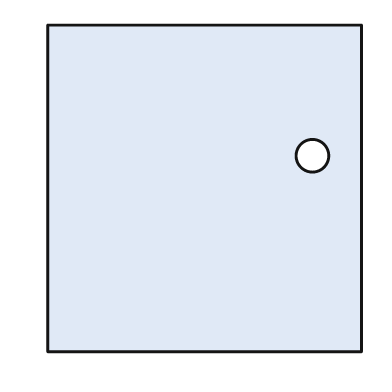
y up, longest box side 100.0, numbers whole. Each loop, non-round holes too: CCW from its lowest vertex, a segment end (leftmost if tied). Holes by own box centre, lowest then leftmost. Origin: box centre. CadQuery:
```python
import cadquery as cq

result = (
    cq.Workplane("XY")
    .moveTo(-48.0, -50.0)
    .lineTo(48.0, -50.0)
    .lineTo(48.0, 50.0)
    .lineTo(-48.0, 50.0)
    .close()
    .moveTo(33.0, 10.0)
    .circle(5.0)
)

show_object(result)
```